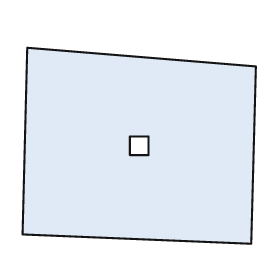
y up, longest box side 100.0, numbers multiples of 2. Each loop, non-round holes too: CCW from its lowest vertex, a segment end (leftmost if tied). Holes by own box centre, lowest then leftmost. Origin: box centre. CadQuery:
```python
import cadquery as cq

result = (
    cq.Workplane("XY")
    .moveTo(48.0, -42.0)
    .lineTo(50.0, 34.0)
    .lineTo(-48.0, 42.0)
    .lineTo(-50.0, -38.0)
    .close()
    .moveTo(-4.0, -4.0)
    .lineTo(4.0, -4.0)
    .lineTo(4.0, 4.0)
    .lineTo(-4.0, 4.0)
    .close()
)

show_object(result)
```